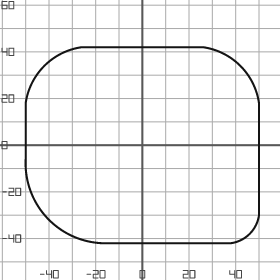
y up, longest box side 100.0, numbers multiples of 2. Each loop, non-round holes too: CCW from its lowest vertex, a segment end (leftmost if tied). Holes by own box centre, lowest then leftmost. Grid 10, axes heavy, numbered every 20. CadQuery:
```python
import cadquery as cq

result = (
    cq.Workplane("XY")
    .moveTo(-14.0, -42.0)
    .lineTo(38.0, -42.0)
    .threePointArc((46.0, -38.0), (50.0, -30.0))
    .lineTo(50.0, 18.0)
    .threePointArc((42.0, 34.0), (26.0, 42.0))
    .lineTo(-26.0, 42.0)
    .threePointArc((-42.0, 34.0), (-50.0, 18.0))
    .lineTo(-50.0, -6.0)
    .threePointArc((-40.0, -32.0), (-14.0, -42.0))
    .close()
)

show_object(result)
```